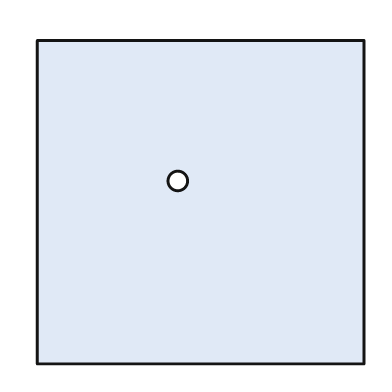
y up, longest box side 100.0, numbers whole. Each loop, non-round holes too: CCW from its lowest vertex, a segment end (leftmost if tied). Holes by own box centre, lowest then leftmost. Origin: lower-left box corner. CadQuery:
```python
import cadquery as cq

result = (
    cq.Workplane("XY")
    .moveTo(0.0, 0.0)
    .lineTo(100.0, 0.0)
    .lineTo(100.0, 99.0)
    .lineTo(0.0, 99.0)
    .close()
    .moveTo(43.0, 56.0)
    .circle(3.0)
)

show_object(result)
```